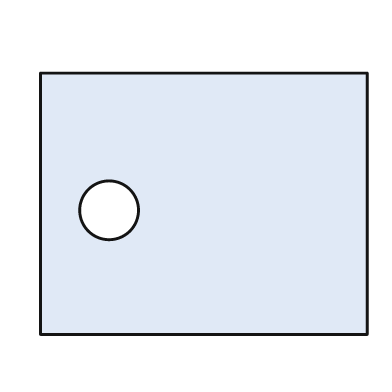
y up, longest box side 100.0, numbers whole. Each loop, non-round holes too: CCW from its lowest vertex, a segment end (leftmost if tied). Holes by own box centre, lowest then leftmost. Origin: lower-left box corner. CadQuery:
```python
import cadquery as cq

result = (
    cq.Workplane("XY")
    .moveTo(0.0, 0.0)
    .lineTo(100.0, 0.0)
    .lineTo(100.0, 80.0)
    .lineTo(0.0, 80.0)
    .close()
    .moveTo(21.0, 38.0)
    .circle(9.0)
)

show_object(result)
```